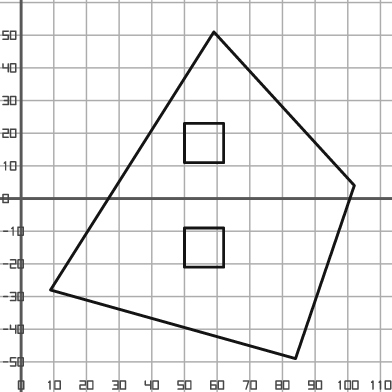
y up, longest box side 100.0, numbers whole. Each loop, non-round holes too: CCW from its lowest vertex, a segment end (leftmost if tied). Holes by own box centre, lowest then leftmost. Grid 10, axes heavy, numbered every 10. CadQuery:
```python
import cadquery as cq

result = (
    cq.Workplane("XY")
    .moveTo(84.0, -49.0)
    .lineTo(102.0, 4.0)
    .lineTo(59.0, 51.0)
    .lineTo(9.0, -28.0)
    .close()
    .moveTo(50.0, -21.0)
    .lineTo(62.0, -21.0)
    .lineTo(62.0, -9.0)
    .lineTo(50.0, -9.0)
    .close()
    .moveTo(50.0, 11.0)
    .lineTo(62.0, 11.0)
    .lineTo(62.0, 23.0)
    .lineTo(50.0, 23.0)
    .close()
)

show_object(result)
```